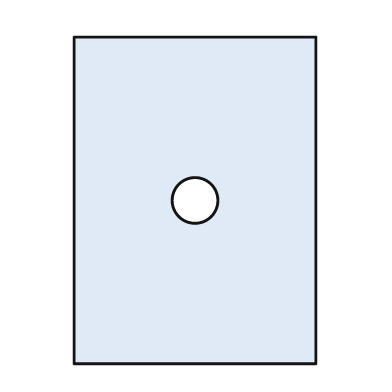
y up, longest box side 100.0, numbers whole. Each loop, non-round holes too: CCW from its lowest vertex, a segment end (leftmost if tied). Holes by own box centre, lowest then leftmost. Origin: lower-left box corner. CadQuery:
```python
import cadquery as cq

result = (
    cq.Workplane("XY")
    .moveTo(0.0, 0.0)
    .lineTo(74.0, 0.0)
    .lineTo(74.0, 100.0)
    .lineTo(0.0, 100.0)
    .close()
    .moveTo(37.0, 50.0)
    .circle(7.0)
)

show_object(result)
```